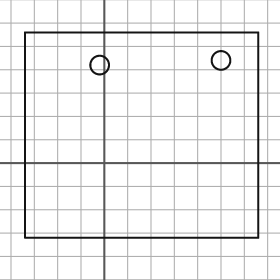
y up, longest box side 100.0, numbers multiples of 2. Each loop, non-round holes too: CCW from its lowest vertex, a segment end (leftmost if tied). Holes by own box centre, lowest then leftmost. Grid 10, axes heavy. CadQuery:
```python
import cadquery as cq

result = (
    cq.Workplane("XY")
    .moveTo(-34.0, -32.0)
    .lineTo(66.0, -32.0)
    .lineTo(66.0, 56.0)
    .lineTo(-34.0, 56.0)
    .close()
    .moveTo(-2.0, 42.0)
    .circle(4.0)
    .moveTo(50.0, 44.0)
    .circle(4.0)
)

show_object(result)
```